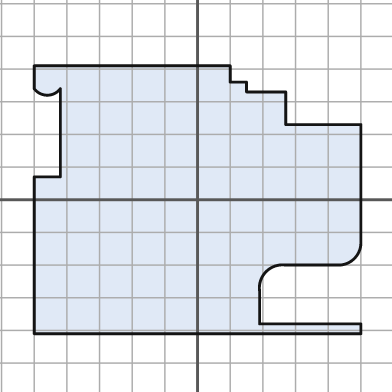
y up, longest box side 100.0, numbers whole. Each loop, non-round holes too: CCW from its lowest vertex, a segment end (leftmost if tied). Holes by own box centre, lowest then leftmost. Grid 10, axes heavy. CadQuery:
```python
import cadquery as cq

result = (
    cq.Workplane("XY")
    .moveTo(-50.0, -41.0)
    .lineTo(50.0, -41.0)
    .lineTo(50.0, -38.0)
    .lineTo(19.0, -38.0)
    .lineTo(19.0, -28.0)
    .threePointArc((21.0, -22.0), (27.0, -20.0))
    .lineTo(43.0, -20.0)
    .threePointArc((48.0, -18.0), (50.0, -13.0))
    .lineTo(50.0, 23.0)
    .lineTo(27.0, 23.0)
    .lineTo(27.0, 33.0)
    .lineTo(15.0, 33.0)
    .lineTo(15.0, 36.0)
    .lineTo(10.0, 36.0)
    .lineTo(10.0, 41.0)
    .lineTo(-50.0, 41.0)
    .lineTo(-50.0, 34.0)
    .threePointArc((-46.0, 32.0), (-42.0, 34.0))
    .lineTo(-42.0, 7.0)
    .lineTo(-50.0, 7.0)
    .close()
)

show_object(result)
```